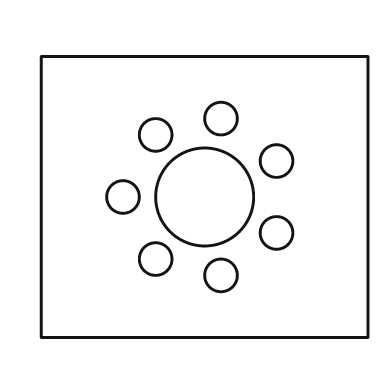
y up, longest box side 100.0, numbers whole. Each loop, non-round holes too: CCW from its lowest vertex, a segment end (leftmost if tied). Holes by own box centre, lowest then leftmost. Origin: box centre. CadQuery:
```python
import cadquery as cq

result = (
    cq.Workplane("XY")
    .moveTo(-50.0, -43.0)
    .lineTo(50.0, -43.0)
    .lineTo(50.0, 43.0)
    .lineTo(-50.0, 43.0)
    .close()
    .moveTo(5.0, -24.0)
    .circle(5.0)
    .moveTo(-15.0, -19.0)
    .circle(5.0)
    .moveTo(22.0, -11.0)
    .circle(5.0)
    .moveTo(-25.0, 0.0)
    .circle(5.0)
    .moveTo(0.0, 0.0)
    .circle(15.0)
    .moveTo(22.0, 11.0)
    .circle(5.0)
    .moveTo(-15.0, 19.0)
    .circle(5.0)
    .moveTo(5.0, 24.0)
    .circle(5.0)
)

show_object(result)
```